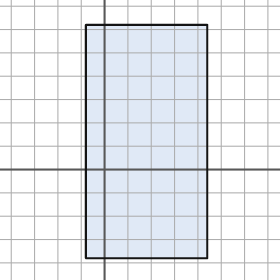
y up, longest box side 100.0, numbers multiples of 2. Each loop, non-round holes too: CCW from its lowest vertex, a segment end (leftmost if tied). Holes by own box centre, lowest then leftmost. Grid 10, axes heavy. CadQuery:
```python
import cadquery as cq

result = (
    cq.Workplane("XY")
    .moveTo(-8.0, -38.0)
    .lineTo(44.0, -38.0)
    .lineTo(44.0, 62.0)
    .lineTo(-8.0, 62.0)
    .close()
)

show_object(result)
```